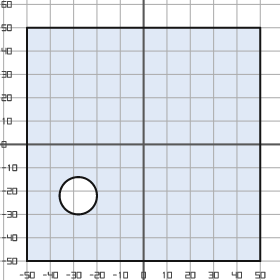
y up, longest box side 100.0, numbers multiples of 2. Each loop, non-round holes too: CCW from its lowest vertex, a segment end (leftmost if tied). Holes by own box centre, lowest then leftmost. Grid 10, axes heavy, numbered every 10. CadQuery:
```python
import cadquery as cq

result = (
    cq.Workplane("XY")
    .moveTo(-50.0, -50.0)
    .lineTo(50.0, -50.0)
    .lineTo(50.0, 50.0)
    .lineTo(-50.0, 50.0)
    .close()
    .moveTo(-28.0, -22.0)
    .circle(8.0)
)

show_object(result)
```